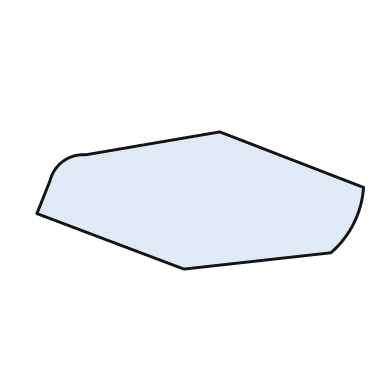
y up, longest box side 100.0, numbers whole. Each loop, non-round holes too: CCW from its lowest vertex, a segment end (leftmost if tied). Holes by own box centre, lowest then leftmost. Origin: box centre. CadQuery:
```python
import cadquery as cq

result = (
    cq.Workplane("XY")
    .moveTo(-5.0, -21.0)
    .lineTo(40.0, -16.0)
    .threePointArc((47.0, -7.0), (50.0, 4.0))
    .lineTo(6.0, 21.0)
    .lineTo(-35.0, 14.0)
    .threePointArc((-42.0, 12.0), (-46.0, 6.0))
    .lineTo(-50.0, -4.0)
    .close()
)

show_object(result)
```